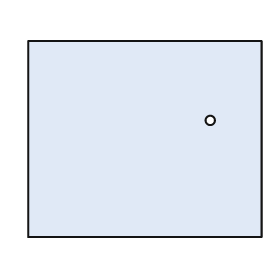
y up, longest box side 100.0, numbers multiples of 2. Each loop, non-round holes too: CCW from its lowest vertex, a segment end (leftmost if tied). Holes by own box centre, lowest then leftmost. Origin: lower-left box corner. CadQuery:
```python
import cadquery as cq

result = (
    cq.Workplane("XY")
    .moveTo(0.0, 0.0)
    .lineTo(100.0, 0.0)
    .lineTo(100.0, 84.0)
    .lineTo(0.0, 84.0)
    .close()
    .moveTo(78.0, 50.0)
    .circle(2.0)
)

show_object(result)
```